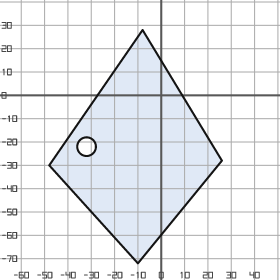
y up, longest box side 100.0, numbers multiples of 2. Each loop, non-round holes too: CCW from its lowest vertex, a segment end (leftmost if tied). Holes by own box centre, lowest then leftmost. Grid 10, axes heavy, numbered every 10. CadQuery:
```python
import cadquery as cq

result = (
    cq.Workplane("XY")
    .moveTo(-10.0, -72.0)
    .lineTo(26.0, -28.0)
    .lineTo(-8.0, 28.0)
    .lineTo(-48.0, -30.0)
    .close()
    .moveTo(-32.0, -22.0)
    .circle(4.0)
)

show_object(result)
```